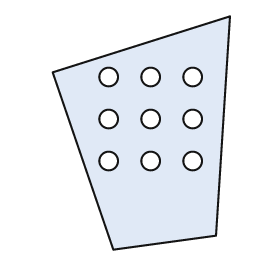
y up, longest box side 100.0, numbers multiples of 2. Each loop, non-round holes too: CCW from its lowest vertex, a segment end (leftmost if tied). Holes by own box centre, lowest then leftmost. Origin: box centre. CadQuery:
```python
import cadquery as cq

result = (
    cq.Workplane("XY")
    .moveTo(-12.0, -50.0)
    .lineTo(32.0, -44.0)
    .lineTo(38.0, 50.0)
    .lineTo(-38.0, 26.0)
    .close()
    .moveTo(-14.0, -12.0)
    .circle(4.0)
    .moveTo(4.0, -12.0)
    .circle(4.0)
    .moveTo(22.0, -12.0)
    .circle(4.0)
    .moveTo(-14.0, 6.0)
    .circle(4.0)
    .moveTo(4.0, 6.0)
    .circle(4.0)
    .moveTo(22.0, 6.0)
    .circle(4.0)
    .moveTo(-14.0, 24.0)
    .circle(4.0)
    .moveTo(4.0, 24.0)
    .circle(4.0)
    .moveTo(22.0, 24.0)
    .circle(4.0)
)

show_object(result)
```